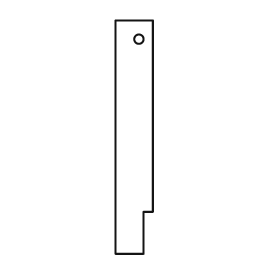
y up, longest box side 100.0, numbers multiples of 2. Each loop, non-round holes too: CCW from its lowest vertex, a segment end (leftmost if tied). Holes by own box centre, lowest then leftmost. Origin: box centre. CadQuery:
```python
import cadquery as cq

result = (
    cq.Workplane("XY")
    .moveTo(-8.0, -50.0)
    .lineTo(4.0, -50.0)
    .lineTo(4.0, -32.0)
    .lineTo(8.0, -32.0)
    .lineTo(8.0, 50.0)
    .lineTo(-8.0, 50.0)
    .close()
    .moveTo(2.0, 42.0)
    .circle(2.0)
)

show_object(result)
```